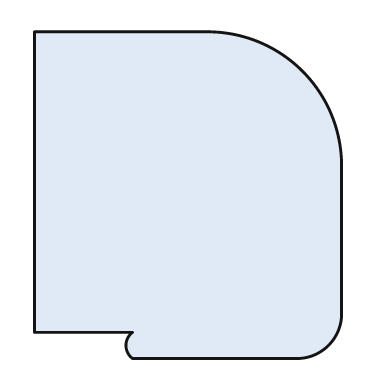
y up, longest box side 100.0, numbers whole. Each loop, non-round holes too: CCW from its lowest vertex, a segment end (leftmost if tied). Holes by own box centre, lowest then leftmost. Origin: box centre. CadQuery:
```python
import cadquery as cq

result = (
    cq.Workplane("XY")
    .moveTo(-17.0, -50.0)
    .lineTo(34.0, -50.0)
    .threePointArc((43.0, -46.0), (47.0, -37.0))
    .lineTo(47.0, 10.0)
    .threePointArc((35.0, 38.0), (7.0, 50.0))
    .lineTo(-47.0, 50.0)
    .lineTo(-47.0, -42.0)
    .lineTo(-17.0, -42.0)
    .threePointArc((-19.0, -46.0), (-17.0, -50.0))
    .close()
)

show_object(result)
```